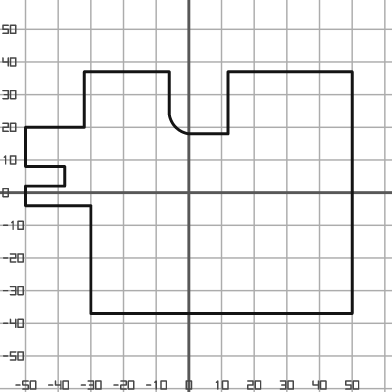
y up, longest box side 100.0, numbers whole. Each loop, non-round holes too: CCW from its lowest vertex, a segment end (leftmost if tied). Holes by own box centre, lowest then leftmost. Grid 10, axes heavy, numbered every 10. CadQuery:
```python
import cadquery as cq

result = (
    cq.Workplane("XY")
    .moveTo(-30.0, -37.0)
    .lineTo(50.0, -37.0)
    .lineTo(50.0, 37.0)
    .lineTo(12.0, 37.0)
    .lineTo(12.0, 18.0)
    .lineTo(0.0, 18.0)
    .threePointArc((-4.0, 20.0), (-6.0, 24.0))
    .lineTo(-6.0, 37.0)
    .lineTo(-32.0, 37.0)
    .lineTo(-32.0, 20.0)
    .lineTo(-50.0, 20.0)
    .lineTo(-50.0, 8.0)
    .lineTo(-38.0, 8.0)
    .lineTo(-38.0, 2.0)
    .lineTo(-50.0, 2.0)
    .lineTo(-50.0, -4.0)
    .lineTo(-30.0, -4.0)
    .close()
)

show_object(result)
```